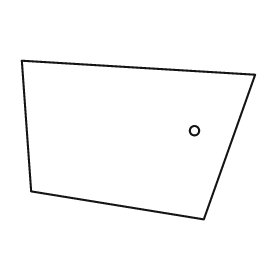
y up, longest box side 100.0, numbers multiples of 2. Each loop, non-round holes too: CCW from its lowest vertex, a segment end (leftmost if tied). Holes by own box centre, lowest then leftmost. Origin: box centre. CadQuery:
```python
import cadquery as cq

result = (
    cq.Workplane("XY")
    .moveTo(28.0, -34.0)
    .lineTo(50.0, 28.0)
    .lineTo(-50.0, 34.0)
    .lineTo(-46.0, -22.0)
    .close()
    .moveTo(24.0, 4.0)
    .circle(2.0)
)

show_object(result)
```